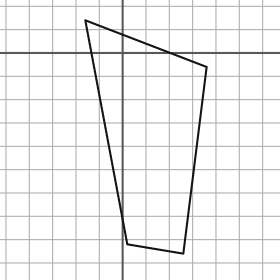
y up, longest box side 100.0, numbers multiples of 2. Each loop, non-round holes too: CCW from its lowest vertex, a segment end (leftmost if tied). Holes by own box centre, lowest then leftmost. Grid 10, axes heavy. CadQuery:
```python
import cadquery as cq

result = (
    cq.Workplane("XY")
    .moveTo(26.0, -86.0)
    .lineTo(36.0, -6.0)
    .lineTo(-16.0, 14.0)
    .lineTo(2.0, -82.0)
    .close()
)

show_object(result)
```